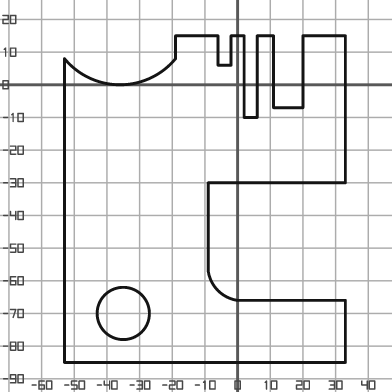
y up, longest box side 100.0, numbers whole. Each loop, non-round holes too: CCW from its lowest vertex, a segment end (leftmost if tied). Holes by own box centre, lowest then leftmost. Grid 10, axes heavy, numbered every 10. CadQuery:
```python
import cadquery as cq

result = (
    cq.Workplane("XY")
    .moveTo(-53.0, -85.0)
    .lineTo(33.0, -85.0)
    .lineTo(33.0, -66.0)
    .lineTo(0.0, -66.0)
    .threePointArc((-6.0, -63.0), (-9.0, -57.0))
    .lineTo(-9.0, -30.0)
    .lineTo(33.0, -30.0)
    .lineTo(33.0, 15.0)
    .lineTo(20.0, 15.0)
    .lineTo(20.0, -7.0)
    .lineTo(11.0, -7.0)
    .lineTo(11.0, 15.0)
    .lineTo(6.0, 15.0)
    .lineTo(6.0, -10.0)
    .lineTo(2.0, -10.0)
    .lineTo(2.0, 15.0)
    .lineTo(-2.0, 15.0)
    .lineTo(-2.0, 6.0)
    .lineTo(-6.0, 6.0)
    .lineTo(-6.0, 15.0)
    .lineTo(-19.0, 15.0)
    .lineTo(-19.0, 8.0)
    .threePointArc((-36.0, 0.0), (-53.0, 8.0))
    .close()
    .moveTo(-35.0, -70.0)
    .circle(8.0)
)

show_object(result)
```